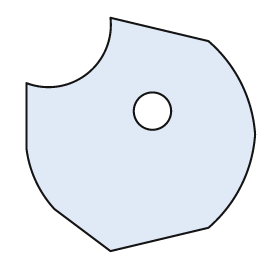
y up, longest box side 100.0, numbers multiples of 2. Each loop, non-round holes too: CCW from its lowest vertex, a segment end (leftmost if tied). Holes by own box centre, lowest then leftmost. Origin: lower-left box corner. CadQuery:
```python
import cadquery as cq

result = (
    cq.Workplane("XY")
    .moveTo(36.0, 0.0)
    .lineTo(78.0, 10.0)
    .threePointArc((92.0, 28.0), (98.0, 50.0))
    .threePointArc((92.0, 72.0), (78.0, 90.0))
    .lineTo(36.0, 100.0)
    .threePointArc((26.0, 76.0), (0.0, 72.0))
    .lineTo(0.0, 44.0)
    .threePointArc((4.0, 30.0), (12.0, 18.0))
    .close()
    .moveTo(54.0, 60.0)
    .circle(8.0)
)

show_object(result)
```